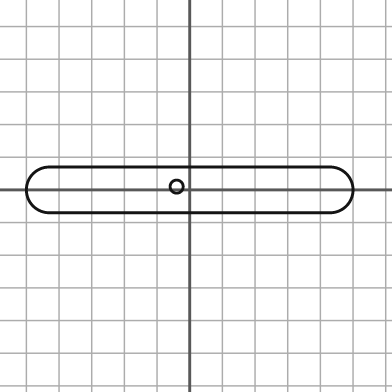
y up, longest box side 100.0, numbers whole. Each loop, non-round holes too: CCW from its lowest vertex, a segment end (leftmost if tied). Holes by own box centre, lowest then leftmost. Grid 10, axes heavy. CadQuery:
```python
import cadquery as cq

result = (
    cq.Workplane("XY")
    .moveTo(-43.0, -7.0)
    .lineTo(43.0, -7.0)
    .threePointArc((50.0, 0.0), (43.0, 7.0))
    .lineTo(-43.0, 7.0)
    .threePointArc((-50.0, 0.0), (-43.0, -7.0))
    .close()
    .moveTo(-4.0, 1.0)
    .circle(2.0)
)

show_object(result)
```